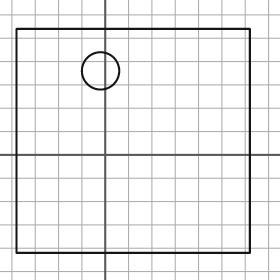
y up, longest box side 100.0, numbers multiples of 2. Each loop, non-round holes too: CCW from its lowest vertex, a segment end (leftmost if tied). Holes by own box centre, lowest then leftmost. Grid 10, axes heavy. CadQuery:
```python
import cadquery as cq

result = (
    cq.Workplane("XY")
    .moveTo(-38.0, -42.0)
    .lineTo(62.0, -42.0)
    .lineTo(62.0, 54.0)
    .lineTo(-38.0, 54.0)
    .close()
    .moveTo(-2.0, 36.0)
    .circle(8.0)
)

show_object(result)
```